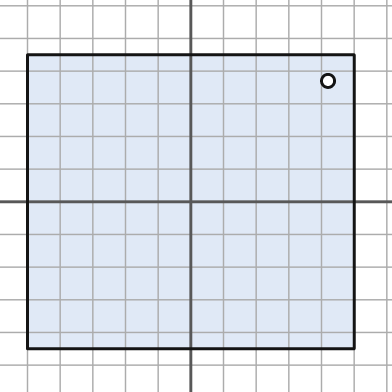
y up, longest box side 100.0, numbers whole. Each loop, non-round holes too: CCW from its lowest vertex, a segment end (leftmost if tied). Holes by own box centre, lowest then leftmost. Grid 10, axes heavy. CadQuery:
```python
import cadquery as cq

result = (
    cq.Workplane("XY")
    .moveTo(-50.0, -45.0)
    .lineTo(50.0, -45.0)
    .lineTo(50.0, 45.0)
    .lineTo(-50.0, 45.0)
    .close()
    .moveTo(42.0, 37.0)
    .circle(2.0)
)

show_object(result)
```